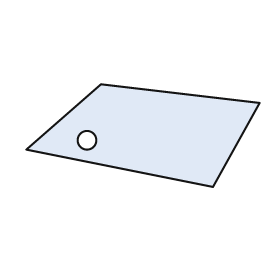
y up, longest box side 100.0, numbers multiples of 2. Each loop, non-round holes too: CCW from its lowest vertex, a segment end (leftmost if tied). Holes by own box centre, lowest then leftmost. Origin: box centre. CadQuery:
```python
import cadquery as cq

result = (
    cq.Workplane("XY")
    .moveTo(30.0, -22.0)
    .lineTo(50.0, 14.0)
    .lineTo(-18.0, 22.0)
    .lineTo(-50.0, -6.0)
    .close()
    .moveTo(-24.0, -2.0)
    .circle(4.0)
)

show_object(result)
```